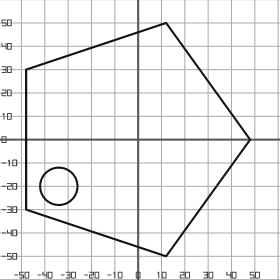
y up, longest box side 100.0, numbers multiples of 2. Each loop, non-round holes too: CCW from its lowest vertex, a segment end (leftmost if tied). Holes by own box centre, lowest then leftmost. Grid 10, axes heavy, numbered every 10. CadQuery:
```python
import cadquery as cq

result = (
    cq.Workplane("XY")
    .moveTo(12.0, -50.0)
    .lineTo(48.0, 0.0)
    .lineTo(12.0, 50.0)
    .lineTo(-48.0, 30.0)
    .lineTo(-48.0, -30.0)
    .close()
    .moveTo(-34.0, -20.0)
    .circle(8.0)
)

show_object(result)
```